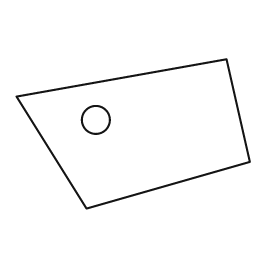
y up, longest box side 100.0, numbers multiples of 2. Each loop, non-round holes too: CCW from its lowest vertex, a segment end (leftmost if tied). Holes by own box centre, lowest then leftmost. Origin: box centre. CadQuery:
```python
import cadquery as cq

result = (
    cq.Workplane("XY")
    .moveTo(-20.0, -32.0)
    .lineTo(50.0, -12.0)
    .lineTo(40.0, 32.0)
    .lineTo(-50.0, 16.0)
    .close()
    .moveTo(-16.0, 6.0)
    .circle(6.0)
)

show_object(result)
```